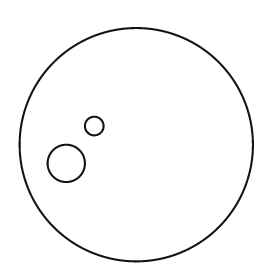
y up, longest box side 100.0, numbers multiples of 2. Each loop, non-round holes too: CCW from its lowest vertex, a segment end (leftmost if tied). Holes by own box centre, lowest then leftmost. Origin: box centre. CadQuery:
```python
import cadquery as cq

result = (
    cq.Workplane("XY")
    .moveTo(0.0, 0.0)
    .circle(50.0)
    .moveTo(-30.0, -8.0)
    .circle(8.0)
    .moveTo(-18.0, 8.0)
    .circle(4.0)
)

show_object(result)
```